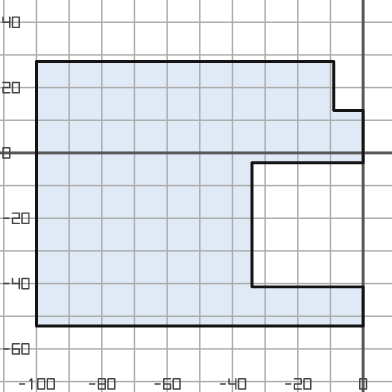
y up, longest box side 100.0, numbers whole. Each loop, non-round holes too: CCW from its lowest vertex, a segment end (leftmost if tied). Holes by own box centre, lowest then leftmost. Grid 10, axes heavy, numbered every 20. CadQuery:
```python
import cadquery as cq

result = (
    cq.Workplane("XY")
    .moveTo(-100.0, -53.0)
    .lineTo(0.0, -53.0)
    .lineTo(0.0, -41.0)
    .lineTo(-34.0, -41.0)
    .lineTo(-34.0, -3.0)
    .lineTo(0.0, -3.0)
    .lineTo(0.0, 13.0)
    .lineTo(-9.0, 13.0)
    .lineTo(-9.0, 28.0)
    .lineTo(-100.0, 28.0)
    .close()
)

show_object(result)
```